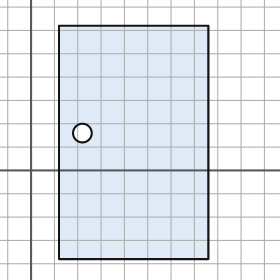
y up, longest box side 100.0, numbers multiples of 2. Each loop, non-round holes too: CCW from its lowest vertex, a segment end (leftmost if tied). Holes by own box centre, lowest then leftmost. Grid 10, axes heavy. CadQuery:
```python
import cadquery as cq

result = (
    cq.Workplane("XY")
    .moveTo(12.0, -38.0)
    .lineTo(76.0, -38.0)
    .lineTo(76.0, 62.0)
    .lineTo(12.0, 62.0)
    .close()
    .moveTo(22.0, 16.0)
    .circle(4.0)
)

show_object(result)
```